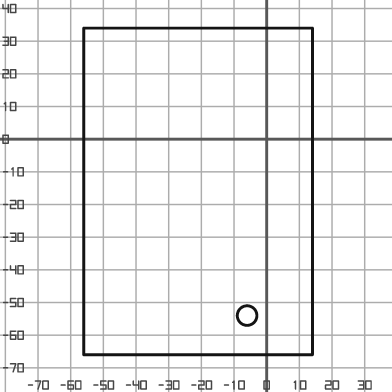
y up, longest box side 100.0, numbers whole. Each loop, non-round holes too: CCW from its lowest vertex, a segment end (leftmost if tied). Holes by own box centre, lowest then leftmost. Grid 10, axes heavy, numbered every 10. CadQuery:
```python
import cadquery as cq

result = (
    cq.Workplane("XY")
    .moveTo(-56.0, -66.0)
    .lineTo(14.0, -66.0)
    .lineTo(14.0, 34.0)
    .lineTo(-56.0, 34.0)
    .close()
    .moveTo(-6.0, -54.0)
    .circle(3.0)
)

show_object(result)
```